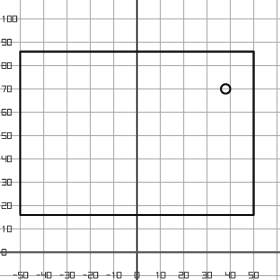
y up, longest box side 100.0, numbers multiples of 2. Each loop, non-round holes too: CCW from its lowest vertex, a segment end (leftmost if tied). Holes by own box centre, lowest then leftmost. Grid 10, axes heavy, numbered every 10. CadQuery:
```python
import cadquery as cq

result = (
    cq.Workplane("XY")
    .moveTo(-50.0, 16.0)
    .lineTo(50.0, 16.0)
    .lineTo(50.0, 86.0)
    .lineTo(-50.0, 86.0)
    .close()
    .moveTo(38.0, 70.0)
    .circle(2.0)
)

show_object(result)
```